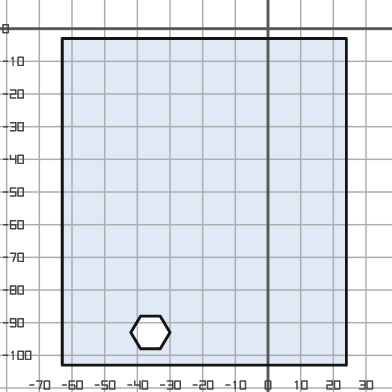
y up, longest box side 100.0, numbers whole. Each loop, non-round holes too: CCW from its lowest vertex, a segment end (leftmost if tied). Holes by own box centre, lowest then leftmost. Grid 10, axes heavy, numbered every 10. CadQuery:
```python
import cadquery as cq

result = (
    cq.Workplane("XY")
    .moveTo(-63.0, -103.0)
    .lineTo(24.0, -103.0)
    .lineTo(24.0, -3.0)
    .lineTo(-63.0, -3.0)
    .close()
    .moveTo(-39.0, -98.0)
    .lineTo(-33.0, -98.0)
    .lineTo(-30.0, -93.0)
    .lineTo(-33.0, -88.0)
    .lineTo(-39.0, -88.0)
    .lineTo(-42.0, -93.0)
    .close()
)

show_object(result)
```